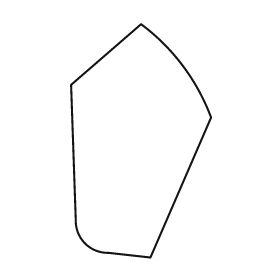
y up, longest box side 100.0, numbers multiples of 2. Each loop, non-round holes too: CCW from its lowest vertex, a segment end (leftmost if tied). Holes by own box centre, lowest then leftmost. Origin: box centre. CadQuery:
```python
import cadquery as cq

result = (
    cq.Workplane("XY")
    .moveTo(4.0, -50.0)
    .lineTo(30.0, 10.0)
    .threePointArc((18.0, 32.0), (0.0, 50.0))
    .lineTo(-30.0, 24.0)
    .lineTo(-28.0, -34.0)
    .threePointArc((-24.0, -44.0), (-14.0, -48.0))
    .close()
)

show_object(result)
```